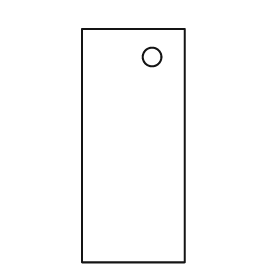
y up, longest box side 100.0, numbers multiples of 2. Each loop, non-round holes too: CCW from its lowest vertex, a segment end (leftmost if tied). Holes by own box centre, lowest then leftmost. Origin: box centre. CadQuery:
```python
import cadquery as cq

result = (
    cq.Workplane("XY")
    .moveTo(-22.0, -50.0)
    .lineTo(22.0, -50.0)
    .lineTo(22.0, 50.0)
    .lineTo(-22.0, 50.0)
    .close()
    .moveTo(8.0, 38.0)
    .circle(4.0)
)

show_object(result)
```